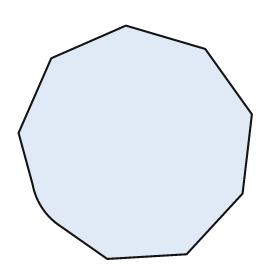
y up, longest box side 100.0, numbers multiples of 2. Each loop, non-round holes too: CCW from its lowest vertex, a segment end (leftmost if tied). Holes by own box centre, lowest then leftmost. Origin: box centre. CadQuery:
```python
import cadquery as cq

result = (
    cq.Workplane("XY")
    .moveTo(-12.0, -50.0)
    .lineTo(22.0, -48.0)
    .lineTo(46.0, -22.0)
    .lineTo(50.0, 12.0)
    .lineTo(30.0, 40.0)
    .lineTo(-4.0, 50.0)
    .lineTo(-36.0, 36.0)
    .lineTo(-50.0, 4.0)
    .lineTo(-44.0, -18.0)
    .threePointArc((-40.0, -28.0), (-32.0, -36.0))
    .close()
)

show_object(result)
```